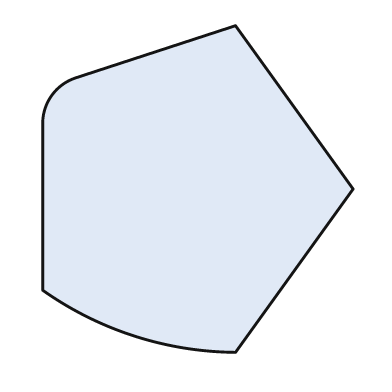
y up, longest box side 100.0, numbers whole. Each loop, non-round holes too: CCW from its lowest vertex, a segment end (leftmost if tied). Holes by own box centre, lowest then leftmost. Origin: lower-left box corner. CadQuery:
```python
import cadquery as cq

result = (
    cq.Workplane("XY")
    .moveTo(59.0, 0.0)
    .lineTo(95.0, 50.0)
    .lineTo(59.0, 100.0)
    .lineTo(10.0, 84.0)
    .threePointArc((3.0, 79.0), (0.0, 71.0))
    .lineTo(0.0, 19.0)
    .threePointArc((28.0, 5.0), (59.0, 0.0))
    .close()
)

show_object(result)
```